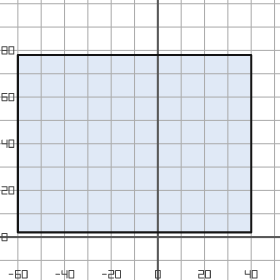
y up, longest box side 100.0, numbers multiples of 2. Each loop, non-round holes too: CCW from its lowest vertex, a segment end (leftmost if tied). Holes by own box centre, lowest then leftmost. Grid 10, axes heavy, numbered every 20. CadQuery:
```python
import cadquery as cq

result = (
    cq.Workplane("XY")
    .moveTo(-60.0, 2.0)
    .lineTo(40.0, 2.0)
    .lineTo(40.0, 78.0)
    .lineTo(-60.0, 78.0)
    .close()
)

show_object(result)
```